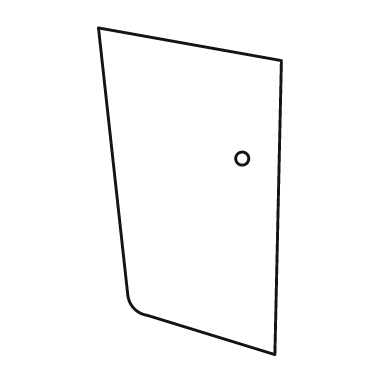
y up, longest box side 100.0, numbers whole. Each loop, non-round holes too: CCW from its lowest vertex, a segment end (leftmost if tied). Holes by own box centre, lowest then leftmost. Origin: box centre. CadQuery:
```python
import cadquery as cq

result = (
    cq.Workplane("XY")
    .moveTo(26.0, -50.0)
    .lineTo(28.0, 40.0)
    .lineTo(-28.0, 50.0)
    .lineTo(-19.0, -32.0)
    .threePointArc((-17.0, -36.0), (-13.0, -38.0))
    .close()
    .moveTo(16.0, 10.0)
    .circle(2.0)
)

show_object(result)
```